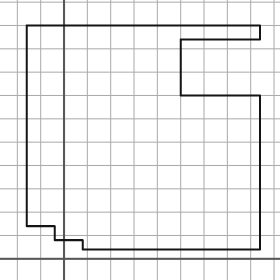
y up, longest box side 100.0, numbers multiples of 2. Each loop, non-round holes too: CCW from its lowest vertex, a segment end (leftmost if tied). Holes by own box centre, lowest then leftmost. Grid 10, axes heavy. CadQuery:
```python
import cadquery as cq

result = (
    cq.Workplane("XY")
    .moveTo(8.0, 4.0)
    .lineTo(84.0, 4.0)
    .lineTo(84.0, 70.0)
    .lineTo(50.0, 70.0)
    .lineTo(50.0, 94.0)
    .lineTo(84.0, 94.0)
    .lineTo(84.0, 100.0)
    .lineTo(-16.0, 100.0)
    .lineTo(-16.0, 14.0)
    .lineTo(-4.0, 14.0)
    .lineTo(-4.0, 8.0)
    .lineTo(8.0, 8.0)
    .close()
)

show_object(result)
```